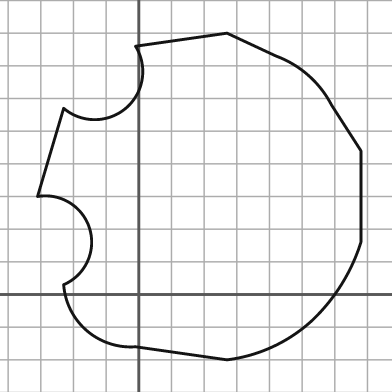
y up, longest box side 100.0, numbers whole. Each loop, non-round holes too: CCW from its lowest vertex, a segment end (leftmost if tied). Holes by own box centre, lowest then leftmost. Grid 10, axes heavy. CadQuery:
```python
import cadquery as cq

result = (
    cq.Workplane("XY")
    .moveTo(27.0, -20.0)
    .threePointArc((41.0, -16.0), (53.0, -8.0))
    .threePointArc((62.0, 3.0), (68.0, 16.0))
    .lineTo(68.0, 44.0)
    .lineTo(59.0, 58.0)
    .threePointArc((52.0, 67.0), (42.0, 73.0))
    .lineTo(27.0, 80.0)
    .lineTo(-1.0, 76.0)
    .threePointArc((-4.0, 57.0), (-23.0, 57.0))
    .lineTo(-31.0, 30.0)
    .threePointArc((-15.0, 20.0), (-23.0, 3.0))
    .threePointArc((-16.0, -11.0), (-1.0, -16.0))
    .close()
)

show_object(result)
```